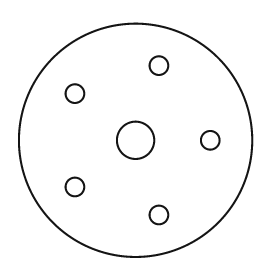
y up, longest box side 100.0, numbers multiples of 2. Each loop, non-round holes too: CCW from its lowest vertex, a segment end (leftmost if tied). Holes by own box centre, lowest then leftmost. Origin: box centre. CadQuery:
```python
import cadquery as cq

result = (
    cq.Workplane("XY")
    .moveTo(0.0, 0.0)
    .circle(50.0)
    .moveTo(10.0, -32.0)
    .circle(4.0)
    .moveTo(-26.0, -20.0)
    .circle(4.0)
    .moveTo(0.0, 0.0)
    .circle(8.0)
    .moveTo(32.0, 0.0)
    .circle(4.0)
    .moveTo(-26.0, 20.0)
    .circle(4.0)
    .moveTo(10.0, 32.0)
    .circle(4.0)
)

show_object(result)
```